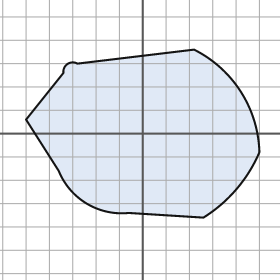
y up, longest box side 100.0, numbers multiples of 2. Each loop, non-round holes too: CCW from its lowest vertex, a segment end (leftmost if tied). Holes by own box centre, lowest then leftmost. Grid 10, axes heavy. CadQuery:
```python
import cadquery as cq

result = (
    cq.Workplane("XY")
    .moveTo(26.0, -36.0)
    .threePointArc((40.0, -24.0), (50.0, -8.0))
    .threePointArc((42.0, 18.0), (22.0, 36.0))
    .lineTo(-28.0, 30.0)
    .threePointArc((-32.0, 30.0), (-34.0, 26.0))
    .lineTo(-50.0, 6.0)
    .lineTo(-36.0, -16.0)
    .threePointArc((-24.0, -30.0), (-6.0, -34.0))
    .close()
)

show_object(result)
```